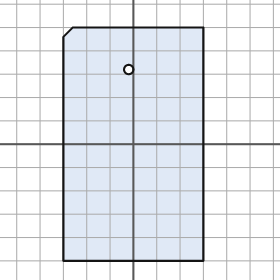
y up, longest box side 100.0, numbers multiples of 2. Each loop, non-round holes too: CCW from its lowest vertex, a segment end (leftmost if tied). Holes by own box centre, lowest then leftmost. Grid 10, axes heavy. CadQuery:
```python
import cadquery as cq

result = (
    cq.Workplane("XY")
    .moveTo(-30.0, -50.0)
    .lineTo(30.0, -50.0)
    .lineTo(30.0, 50.0)
    .lineTo(-26.0, 50.0)
    .lineTo(-30.0, 46.0)
    .close()
    .moveTo(-2.0, 32.0)
    .circle(2.0)
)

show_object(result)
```